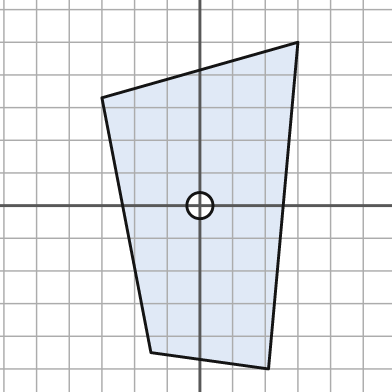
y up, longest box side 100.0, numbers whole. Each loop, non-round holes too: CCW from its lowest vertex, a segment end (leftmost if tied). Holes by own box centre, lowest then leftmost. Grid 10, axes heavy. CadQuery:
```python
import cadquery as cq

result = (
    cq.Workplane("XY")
    .moveTo(21.0, -50.0)
    .lineTo(30.0, 50.0)
    .lineTo(-30.0, 33.0)
    .lineTo(-15.0, -45.0)
    .close()
    .moveTo(0.0, 0.0)
    .circle(4.0)
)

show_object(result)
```